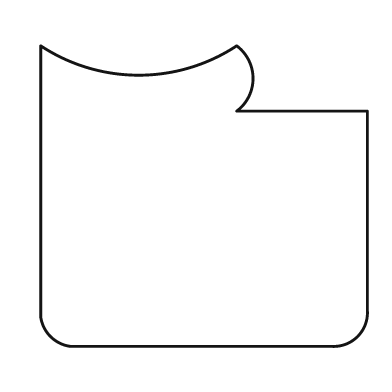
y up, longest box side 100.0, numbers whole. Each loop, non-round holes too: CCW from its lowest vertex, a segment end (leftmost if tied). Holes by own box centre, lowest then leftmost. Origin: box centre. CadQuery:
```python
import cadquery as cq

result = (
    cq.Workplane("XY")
    .moveTo(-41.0, -46.0)
    .lineTo(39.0, -46.0)
    .threePointArc((47.0, -43.0), (50.0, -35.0))
    .lineTo(50.0, 26.0)
    .lineTo(10.0, 26.0)
    .threePointArc((15.0, 36.0), (10.0, 46.0))
    .threePointArc((-20.0, 37.0), (-50.0, 46.0))
    .lineTo(-50.0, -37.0)
    .threePointArc((-47.0, -43.0), (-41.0, -46.0))
    .close()
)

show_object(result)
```